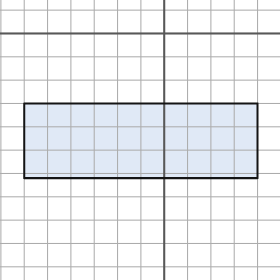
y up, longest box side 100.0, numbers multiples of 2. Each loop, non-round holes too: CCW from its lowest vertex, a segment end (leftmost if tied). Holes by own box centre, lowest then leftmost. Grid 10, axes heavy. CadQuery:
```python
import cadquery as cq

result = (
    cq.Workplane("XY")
    .moveTo(-60.0, -62.0)
    .lineTo(40.0, -62.0)
    .lineTo(40.0, -30.0)
    .lineTo(-60.0, -30.0)
    .close()
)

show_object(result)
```